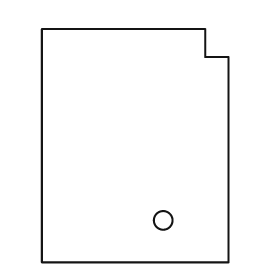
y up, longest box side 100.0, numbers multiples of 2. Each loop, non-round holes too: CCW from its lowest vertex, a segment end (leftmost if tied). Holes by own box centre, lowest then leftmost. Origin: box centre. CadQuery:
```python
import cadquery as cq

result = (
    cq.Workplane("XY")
    .moveTo(-40.0, -50.0)
    .lineTo(40.0, -50.0)
    .lineTo(40.0, 38.0)
    .lineTo(30.0, 38.0)
    .lineTo(30.0, 50.0)
    .lineTo(-40.0, 50.0)
    .close()
    .moveTo(12.0, -32.0)
    .circle(4.0)
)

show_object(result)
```